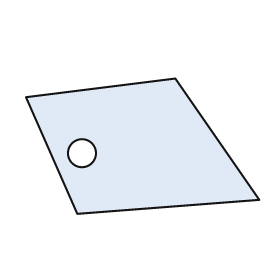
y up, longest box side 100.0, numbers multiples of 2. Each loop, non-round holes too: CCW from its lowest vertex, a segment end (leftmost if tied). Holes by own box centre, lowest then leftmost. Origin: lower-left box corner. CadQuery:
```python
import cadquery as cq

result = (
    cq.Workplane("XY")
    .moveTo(22.0, 0.0)
    .lineTo(100.0, 6.0)
    .lineTo(64.0, 58.0)
    .lineTo(0.0, 50.0)
    .close()
    .moveTo(24.0, 26.0)
    .circle(6.0)
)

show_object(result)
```